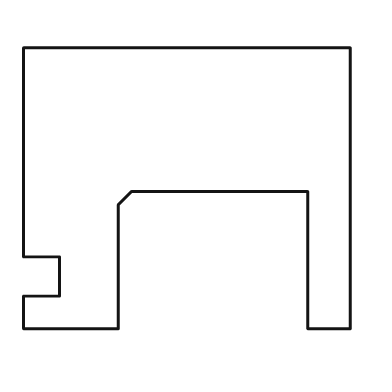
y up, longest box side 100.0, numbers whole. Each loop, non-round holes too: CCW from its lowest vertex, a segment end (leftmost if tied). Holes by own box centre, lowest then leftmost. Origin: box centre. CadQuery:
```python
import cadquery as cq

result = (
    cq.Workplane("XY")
    .moveTo(-50.0, -43.0)
    .lineTo(-21.0, -43.0)
    .lineTo(-21.0, -5.0)
    .lineTo(-17.0, -1.0)
    .lineTo(37.0, -1.0)
    .lineTo(37.0, -43.0)
    .lineTo(50.0, -43.0)
    .lineTo(50.0, 43.0)
    .lineTo(-50.0, 43.0)
    .lineTo(-50.0, -21.0)
    .lineTo(-39.0, -21.0)
    .lineTo(-39.0, -33.0)
    .lineTo(-50.0, -33.0)
    .close()
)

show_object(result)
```